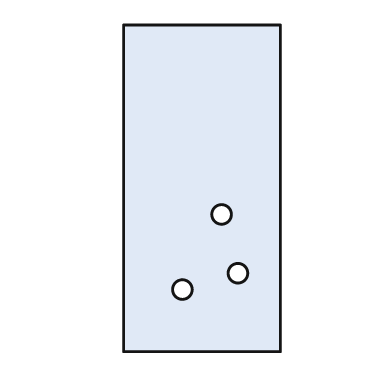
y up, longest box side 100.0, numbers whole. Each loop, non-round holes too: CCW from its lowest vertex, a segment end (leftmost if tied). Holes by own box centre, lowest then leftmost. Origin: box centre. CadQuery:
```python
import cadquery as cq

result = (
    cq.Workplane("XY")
    .moveTo(-24.0, -50.0)
    .lineTo(24.0, -50.0)
    .lineTo(24.0, 50.0)
    .lineTo(-24.0, 50.0)
    .close()
    .moveTo(-6.0, -31.0)
    .circle(3.0)
    .moveTo(11.0, -26.0)
    .circle(3.0)
    .moveTo(6.0, -8.0)
    .circle(3.0)
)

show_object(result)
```